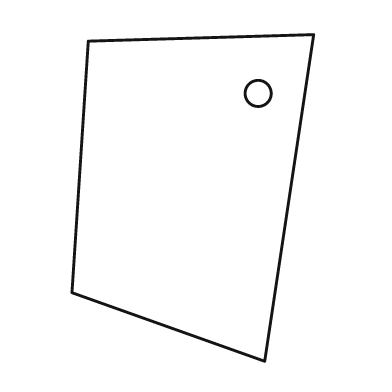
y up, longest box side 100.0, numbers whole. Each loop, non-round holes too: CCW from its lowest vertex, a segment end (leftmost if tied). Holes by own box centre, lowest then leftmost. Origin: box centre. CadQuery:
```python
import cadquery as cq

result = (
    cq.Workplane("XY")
    .moveTo(22.0, -50.0)
    .lineTo(37.0, 50.0)
    .lineTo(-32.0, 48.0)
    .lineTo(-37.0, -29.0)
    .close()
    .moveTo(20.0, 32.0)
    .circle(4.0)
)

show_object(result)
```